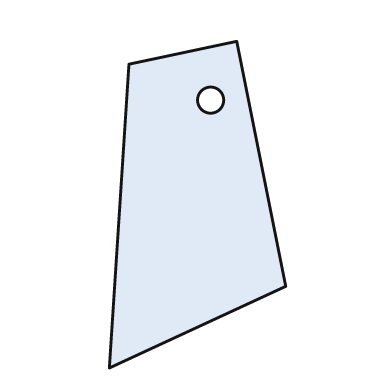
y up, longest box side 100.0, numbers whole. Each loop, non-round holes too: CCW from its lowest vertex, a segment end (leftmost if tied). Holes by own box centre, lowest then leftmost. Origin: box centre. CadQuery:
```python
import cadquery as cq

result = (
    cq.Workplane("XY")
    .moveTo(-27.0, -50.0)
    .lineTo(27.0, -25.0)
    .lineTo(12.0, 50.0)
    .lineTo(-21.0, 43.0)
    .close()
    .moveTo(4.0, 32.0)
    .circle(4.0)
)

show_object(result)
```